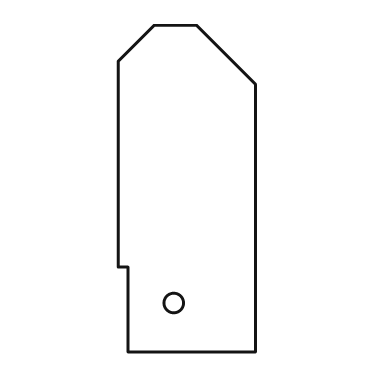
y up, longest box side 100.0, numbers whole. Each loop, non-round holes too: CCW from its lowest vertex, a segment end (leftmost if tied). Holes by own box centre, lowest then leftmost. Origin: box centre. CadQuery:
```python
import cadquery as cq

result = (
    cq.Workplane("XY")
    .moveTo(-18.0, -50.0)
    .lineTo(21.0, -50.0)
    .lineTo(21.0, 32.0)
    .lineTo(3.0, 50.0)
    .lineTo(-10.0, 50.0)
    .lineTo(-21.0, 39.0)
    .lineTo(-21.0, -24.0)
    .lineTo(-18.0, -24.0)
    .close()
    .moveTo(-4.0, -35.0)
    .circle(3.0)
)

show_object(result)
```